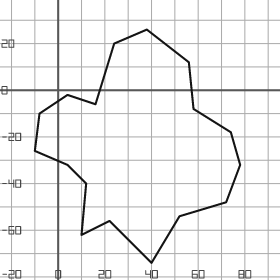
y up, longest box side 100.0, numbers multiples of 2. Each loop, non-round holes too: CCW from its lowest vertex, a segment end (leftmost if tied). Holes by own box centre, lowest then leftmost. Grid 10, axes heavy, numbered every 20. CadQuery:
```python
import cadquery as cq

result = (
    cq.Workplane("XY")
    .moveTo(40.0, -74.0)
    .lineTo(52.0, -54.0)
    .lineTo(72.0, -48.0)
    .lineTo(78.0, -32.0)
    .lineTo(74.0, -18.0)
    .lineTo(58.0, -8.0)
    .lineTo(56.0, 12.0)
    .lineTo(38.0, 26.0)
    .lineTo(24.0, 20.0)
    .lineTo(16.0, -6.0)
    .lineTo(4.0, -2.0)
    .lineTo(-8.0, -10.0)
    .lineTo(-10.0, -26.0)
    .lineTo(4.0, -32.0)
    .lineTo(12.0, -40.0)
    .lineTo(10.0, -62.0)
    .lineTo(22.0, -56.0)
    .close()
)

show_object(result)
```